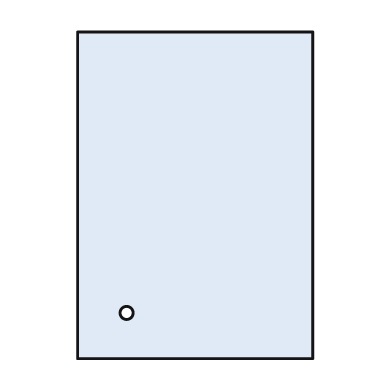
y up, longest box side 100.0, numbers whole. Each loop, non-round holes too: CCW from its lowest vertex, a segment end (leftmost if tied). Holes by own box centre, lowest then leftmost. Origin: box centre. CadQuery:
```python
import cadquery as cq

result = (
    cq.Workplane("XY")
    .moveTo(-36.0, -50.0)
    .lineTo(36.0, -50.0)
    .lineTo(36.0, 50.0)
    .lineTo(-36.0, 50.0)
    .close()
    .moveTo(-21.0, -36.0)
    .circle(2.0)
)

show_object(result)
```